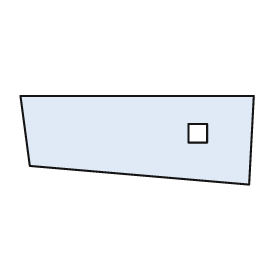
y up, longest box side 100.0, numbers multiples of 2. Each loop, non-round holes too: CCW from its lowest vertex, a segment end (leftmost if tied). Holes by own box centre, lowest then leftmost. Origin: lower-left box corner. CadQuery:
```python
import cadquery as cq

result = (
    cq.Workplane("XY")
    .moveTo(98.0, 0.0)
    .lineTo(100.0, 38.0)
    .lineTo(0.0, 38.0)
    .lineTo(4.0, 8.0)
    .close()
    .moveTo(72.0, 18.0)
    .lineTo(80.0, 18.0)
    .lineTo(80.0, 26.0)
    .lineTo(72.0, 26.0)
    .close()
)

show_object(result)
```